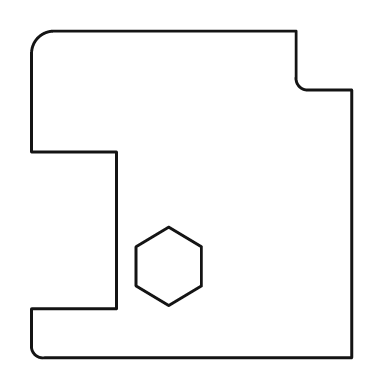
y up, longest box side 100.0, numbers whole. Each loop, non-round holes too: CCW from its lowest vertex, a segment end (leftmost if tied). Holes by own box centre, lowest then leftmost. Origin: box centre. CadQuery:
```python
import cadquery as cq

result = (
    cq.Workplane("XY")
    .moveTo(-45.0, -50.0)
    .lineTo(49.0, -50.0)
    .lineTo(49.0, 32.0)
    .lineTo(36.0, 32.0)
    .threePointArc((33.0, 33.0), (32.0, 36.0))
    .lineTo(32.0, 50.0)
    .lineTo(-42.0, 50.0)
    .threePointArc((-47.0, 48.0), (-49.0, 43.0))
    .lineTo(-49.0, 13.0)
    .lineTo(-23.0, 13.0)
    .lineTo(-23.0, -35.0)
    .lineTo(-49.0, -35.0)
    .lineTo(-49.0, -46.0)
    .threePointArc((-48.0, -49.0), (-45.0, -50.0))
    .close()
    .moveTo(-7.0, -34.0)
    .lineTo(3.0, -28.0)
    .lineTo(3.0, -16.0)
    .lineTo(-7.0, -10.0)
    .lineTo(-17.0, -16.0)
    .lineTo(-17.0, -28.0)
    .close()
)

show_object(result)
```